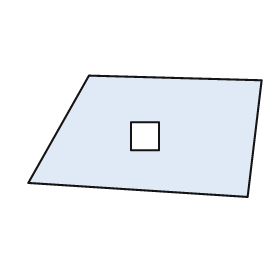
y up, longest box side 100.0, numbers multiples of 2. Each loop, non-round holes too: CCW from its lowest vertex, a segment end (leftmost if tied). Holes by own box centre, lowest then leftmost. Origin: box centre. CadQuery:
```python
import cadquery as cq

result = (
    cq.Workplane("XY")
    .moveTo(44.0, -26.0)
    .lineTo(50.0, 24.0)
    .lineTo(-24.0, 26.0)
    .lineTo(-50.0, -20.0)
    .close()
    .moveTo(-6.0, -6.0)
    .lineTo(6.0, -6.0)
    .lineTo(6.0, 6.0)
    .lineTo(-6.0, 6.0)
    .close()
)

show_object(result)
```